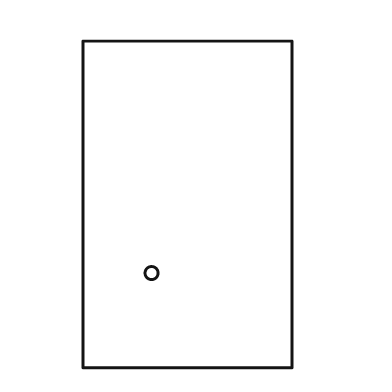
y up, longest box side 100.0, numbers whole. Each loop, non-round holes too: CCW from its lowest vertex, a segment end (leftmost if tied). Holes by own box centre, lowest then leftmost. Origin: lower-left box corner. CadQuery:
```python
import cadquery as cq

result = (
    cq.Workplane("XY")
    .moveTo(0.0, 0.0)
    .lineTo(64.0, 0.0)
    .lineTo(64.0, 100.0)
    .lineTo(0.0, 100.0)
    .close()
    .moveTo(21.0, 29.0)
    .circle(2.0)
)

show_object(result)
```